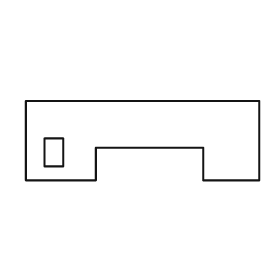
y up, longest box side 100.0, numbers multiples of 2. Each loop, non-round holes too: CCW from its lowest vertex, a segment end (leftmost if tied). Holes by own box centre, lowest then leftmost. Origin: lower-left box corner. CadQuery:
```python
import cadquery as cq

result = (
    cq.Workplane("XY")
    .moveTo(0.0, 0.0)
    .lineTo(30.0, 0.0)
    .lineTo(30.0, 14.0)
    .lineTo(76.0, 14.0)
    .lineTo(76.0, 0.0)
    .lineTo(100.0, 0.0)
    .lineTo(100.0, 34.0)
    .lineTo(0.0, 34.0)
    .close()
    .moveTo(8.0, 6.0)
    .lineTo(16.0, 6.0)
    .lineTo(16.0, 18.0)
    .lineTo(8.0, 18.0)
    .close()
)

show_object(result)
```